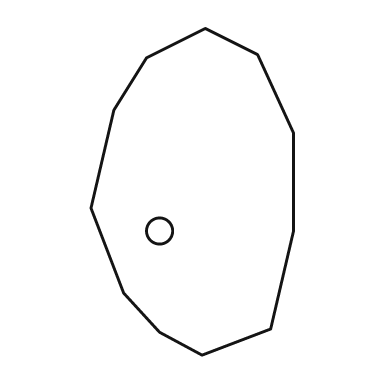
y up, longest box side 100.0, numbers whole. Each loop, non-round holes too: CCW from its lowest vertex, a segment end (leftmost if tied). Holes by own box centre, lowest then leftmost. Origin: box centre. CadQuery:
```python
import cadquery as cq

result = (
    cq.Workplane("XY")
    .moveTo(3.0, -50.0)
    .lineTo(24.0, -42.0)
    .lineTo(31.0, -12.0)
    .lineTo(31.0, 18.0)
    .lineTo(20.0, 42.0)
    .lineTo(4.0, 50.0)
    .lineTo(-14.0, 41.0)
    .lineTo(-24.0, 25.0)
    .lineTo(-31.0, -5.0)
    .lineTo(-21.0, -31.0)
    .lineTo(-10.0, -43.0)
    .close()
    .moveTo(-10.0, -12.0)
    .circle(4.0)
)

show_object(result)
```